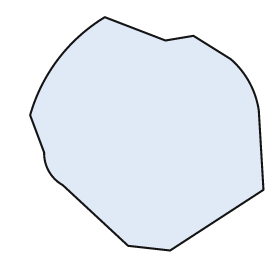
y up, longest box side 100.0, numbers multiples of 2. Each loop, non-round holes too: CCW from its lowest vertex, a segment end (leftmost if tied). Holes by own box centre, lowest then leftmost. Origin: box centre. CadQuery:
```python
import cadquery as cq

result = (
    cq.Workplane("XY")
    .moveTo(10.0, -50.0)
    .lineTo(50.0, -24.0)
    .lineTo(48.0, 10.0)
    .threePointArc((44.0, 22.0), (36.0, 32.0))
    .lineTo(20.0, 42.0)
    .lineTo(8.0, 40.0)
    .lineTo(-18.0, 50.0)
    .threePointArc((-38.0, 32.0), (-50.0, 8.0))
    .lineTo(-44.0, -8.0)
    .threePointArc((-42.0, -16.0), (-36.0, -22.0))
    .lineTo(-8.0, -48.0)
    .close()
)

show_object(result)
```